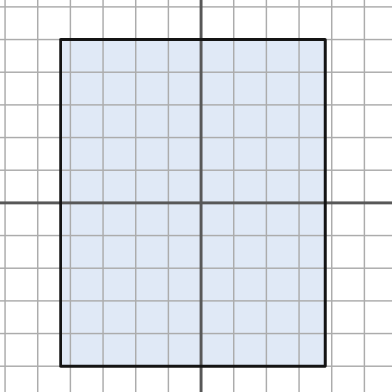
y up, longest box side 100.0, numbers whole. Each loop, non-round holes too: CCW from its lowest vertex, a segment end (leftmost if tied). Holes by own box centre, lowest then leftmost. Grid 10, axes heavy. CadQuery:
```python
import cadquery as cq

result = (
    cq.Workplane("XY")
    .moveTo(-43.0, -50.0)
    .lineTo(38.0, -50.0)
    .lineTo(38.0, 50.0)
    .lineTo(-43.0, 50.0)
    .close()
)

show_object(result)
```